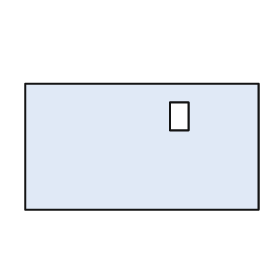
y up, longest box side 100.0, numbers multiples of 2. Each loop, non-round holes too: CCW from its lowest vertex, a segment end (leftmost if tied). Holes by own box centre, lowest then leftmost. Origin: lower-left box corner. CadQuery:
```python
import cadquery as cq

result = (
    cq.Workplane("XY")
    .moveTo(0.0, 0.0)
    .lineTo(100.0, 0.0)
    .lineTo(100.0, 54.0)
    .lineTo(0.0, 54.0)
    .close()
    .moveTo(62.0, 34.0)
    .lineTo(70.0, 34.0)
    .lineTo(70.0, 46.0)
    .lineTo(62.0, 46.0)
    .close()
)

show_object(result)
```